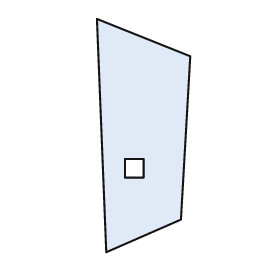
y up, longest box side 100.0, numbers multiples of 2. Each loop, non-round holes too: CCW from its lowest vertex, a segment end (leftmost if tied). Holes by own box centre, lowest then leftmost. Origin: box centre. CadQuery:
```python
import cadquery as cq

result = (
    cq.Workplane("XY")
    .moveTo(-16.0, -50.0)
    .lineTo(16.0, -36.0)
    .lineTo(20.0, 34.0)
    .lineTo(-20.0, 50.0)
    .close()
    .moveTo(-8.0, -18.0)
    .lineTo(0.0, -18.0)
    .lineTo(0.0, -10.0)
    .lineTo(-8.0, -10.0)
    .close()
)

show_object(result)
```